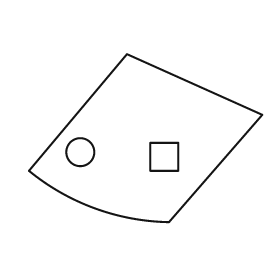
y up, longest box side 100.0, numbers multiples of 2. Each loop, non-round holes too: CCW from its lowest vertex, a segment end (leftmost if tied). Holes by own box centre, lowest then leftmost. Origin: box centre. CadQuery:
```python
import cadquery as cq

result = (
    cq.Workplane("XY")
    .moveTo(10.0, -36.0)
    .lineTo(50.0, 10.0)
    .lineTo(-8.0, 36.0)
    .lineTo(-50.0, -14.0)
    .threePointArc((-22.0, -30.0), (10.0, -36.0))
    .close()
    .moveTo(2.0, -14.0)
    .lineTo(14.0, -14.0)
    .lineTo(14.0, -2.0)
    .lineTo(2.0, -2.0)
    .close()
    .moveTo(-28.0, -6.0)
    .circle(6.0)
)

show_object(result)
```